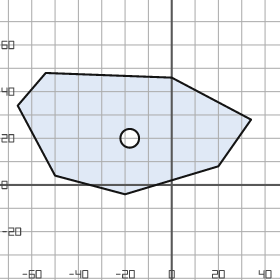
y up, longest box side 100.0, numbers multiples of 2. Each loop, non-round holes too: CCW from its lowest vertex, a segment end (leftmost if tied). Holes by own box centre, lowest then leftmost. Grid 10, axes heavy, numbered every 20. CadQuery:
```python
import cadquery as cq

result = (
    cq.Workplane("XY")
    .moveTo(-20.0, -4.0)
    .lineTo(20.0, 8.0)
    .lineTo(34.0, 28.0)
    .lineTo(0.0, 46.0)
    .lineTo(-54.0, 48.0)
    .lineTo(-66.0, 34.0)
    .lineTo(-50.0, 4.0)
    .close()
    .moveTo(-18.0, 20.0)
    .circle(4.0)
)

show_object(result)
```